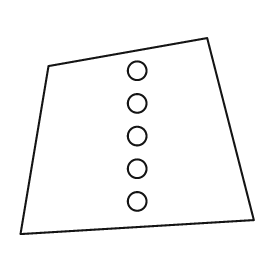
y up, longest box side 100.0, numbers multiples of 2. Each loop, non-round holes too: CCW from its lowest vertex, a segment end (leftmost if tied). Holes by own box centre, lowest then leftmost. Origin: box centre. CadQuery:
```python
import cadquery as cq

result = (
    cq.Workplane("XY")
    .moveTo(-50.0, -42.0)
    .lineTo(50.0, -36.0)
    .lineTo(30.0, 42.0)
    .lineTo(-38.0, 30.0)
    .close()
    .moveTo(0.0, -28.0)
    .circle(4.0)
    .moveTo(0.0, -14.0)
    .circle(4.0)
    .moveTo(0.0, 0.0)
    .circle(4.0)
    .moveTo(0.0, 14.0)
    .circle(4.0)
    .moveTo(0.0, 28.0)
    .circle(4.0)
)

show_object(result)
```